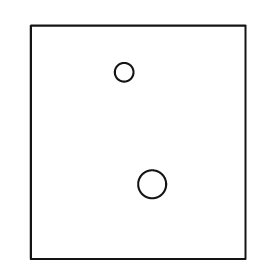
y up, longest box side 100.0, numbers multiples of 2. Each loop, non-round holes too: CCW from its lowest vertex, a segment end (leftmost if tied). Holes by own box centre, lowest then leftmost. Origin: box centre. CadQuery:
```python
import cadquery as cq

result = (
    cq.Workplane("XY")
    .moveTo(-46.0, -50.0)
    .lineTo(46.0, -50.0)
    .lineTo(46.0, 50.0)
    .lineTo(-46.0, 50.0)
    .close()
    .moveTo(6.0, -18.0)
    .circle(6.0)
    .moveTo(-6.0, 30.0)
    .circle(4.0)
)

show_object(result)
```